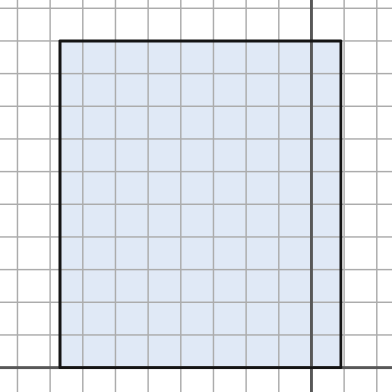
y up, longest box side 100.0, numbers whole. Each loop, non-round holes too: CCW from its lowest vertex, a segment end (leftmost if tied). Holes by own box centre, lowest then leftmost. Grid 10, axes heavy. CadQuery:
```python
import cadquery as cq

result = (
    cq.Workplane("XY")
    .moveTo(-77.0, 0.0)
    .lineTo(9.0, 0.0)
    .lineTo(9.0, 100.0)
    .lineTo(-77.0, 100.0)
    .close()
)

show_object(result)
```